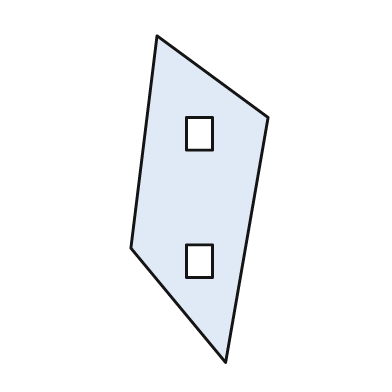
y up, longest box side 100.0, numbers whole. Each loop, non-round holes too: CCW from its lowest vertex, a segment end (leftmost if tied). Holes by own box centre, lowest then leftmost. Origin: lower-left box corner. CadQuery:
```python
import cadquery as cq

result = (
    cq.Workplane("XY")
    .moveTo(29.0, 0.0)
    .lineTo(42.0, 75.0)
    .lineTo(8.0, 100.0)
    .lineTo(0.0, 35.0)
    .close()
    .moveTo(17.0, 26.0)
    .lineTo(25.0, 26.0)
    .lineTo(25.0, 36.0)
    .lineTo(17.0, 36.0)
    .close()
    .moveTo(17.0, 65.0)
    .lineTo(25.0, 65.0)
    .lineTo(25.0, 75.0)
    .lineTo(17.0, 75.0)
    .close()
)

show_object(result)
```